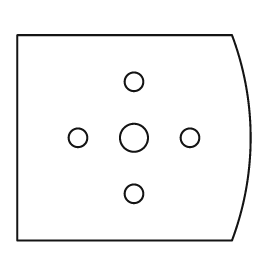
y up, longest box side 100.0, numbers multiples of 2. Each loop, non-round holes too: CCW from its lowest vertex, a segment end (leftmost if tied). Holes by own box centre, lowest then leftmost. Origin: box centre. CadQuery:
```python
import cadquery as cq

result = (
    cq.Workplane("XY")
    .moveTo(-50.0, -44.0)
    .lineTo(42.0, -44.0)
    .threePointArc((50.0, 0.0), (42.0, 44.0))
    .lineTo(-50.0, 44.0)
    .close()
    .moveTo(0.0, -24.0)
    .circle(4.0)
    .moveTo(-24.0, 0.0)
    .circle(4.0)
    .moveTo(0.0, 0.0)
    .circle(6.0)
    .moveTo(24.0, 0.0)
    .circle(4.0)
    .moveTo(0.0, 24.0)
    .circle(4.0)
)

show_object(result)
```